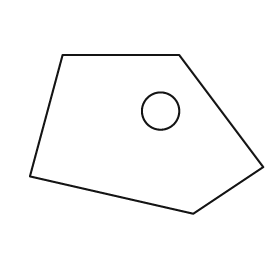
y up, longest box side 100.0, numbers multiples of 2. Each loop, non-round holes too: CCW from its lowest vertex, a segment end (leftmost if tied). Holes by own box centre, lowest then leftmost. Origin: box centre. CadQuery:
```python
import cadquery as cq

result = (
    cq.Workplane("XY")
    .moveTo(20.0, -34.0)
    .lineTo(50.0, -14.0)
    .lineTo(14.0, 34.0)
    .lineTo(-36.0, 34.0)
    .lineTo(-50.0, -18.0)
    .close()
    .moveTo(6.0, 10.0)
    .circle(8.0)
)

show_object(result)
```